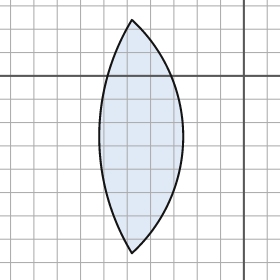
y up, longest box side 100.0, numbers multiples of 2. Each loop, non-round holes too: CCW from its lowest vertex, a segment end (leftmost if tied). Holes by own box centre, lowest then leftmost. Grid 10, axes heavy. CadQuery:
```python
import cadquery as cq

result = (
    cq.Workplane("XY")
    .moveTo(-48.0, -76.0)
    .threePointArc((-26.0, -26.0), (-48.0, 24.0))
    .threePointArc((-62.0, -26.0), (-48.0, -76.0))
    .close()
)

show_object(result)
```